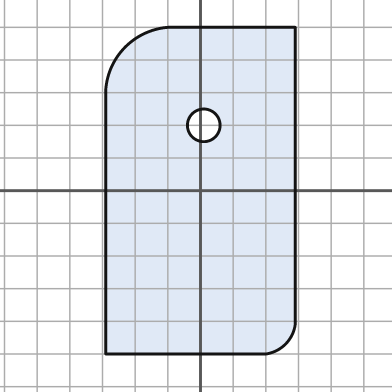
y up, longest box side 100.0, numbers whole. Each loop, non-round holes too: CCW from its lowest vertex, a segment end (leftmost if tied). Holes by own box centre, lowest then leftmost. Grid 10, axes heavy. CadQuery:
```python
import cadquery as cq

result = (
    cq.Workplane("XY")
    .moveTo(-29.0, -50.0)
    .lineTo(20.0, -50.0)
    .threePointArc((26.0, -47.0), (29.0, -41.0))
    .lineTo(29.0, 50.0)
    .lineTo(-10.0, 50.0)
    .threePointArc((-23.0, 44.0), (-29.0, 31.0))
    .close()
    .moveTo(1.0, 20.0)
    .circle(5.0)
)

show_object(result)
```